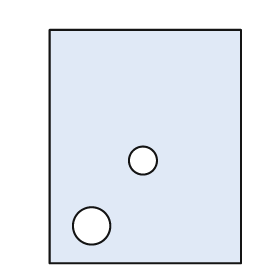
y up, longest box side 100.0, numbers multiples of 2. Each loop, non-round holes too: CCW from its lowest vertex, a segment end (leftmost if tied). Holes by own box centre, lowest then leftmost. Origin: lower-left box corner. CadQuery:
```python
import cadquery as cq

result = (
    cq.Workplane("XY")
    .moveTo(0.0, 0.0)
    .lineTo(82.0, 0.0)
    .lineTo(82.0, 100.0)
    .lineTo(0.0, 100.0)
    .close()
    .moveTo(18.0, 16.0)
    .circle(8.0)
    .moveTo(40.0, 44.0)
    .circle(6.0)
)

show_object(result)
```